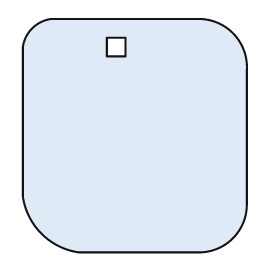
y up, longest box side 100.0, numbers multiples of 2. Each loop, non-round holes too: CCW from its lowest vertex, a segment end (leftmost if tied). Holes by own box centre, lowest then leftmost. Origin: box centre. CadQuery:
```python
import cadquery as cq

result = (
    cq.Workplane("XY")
    .moveTo(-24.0, -50.0)
    .lineTo(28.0, -50.0)
    .threePointArc((42.0, -44.0), (48.0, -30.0))
    .lineTo(48.0, 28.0)
    .threePointArc((42.0, 44.0), (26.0, 50.0))
    .lineTo(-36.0, 50.0)
    .threePointArc((-44.0, 46.0), (-48.0, 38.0))
    .lineTo(-48.0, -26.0)
    .threePointArc((-40.0, -42.0), (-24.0, -50.0))
    .close()
    .moveTo(-12.0, 34.0)
    .lineTo(-4.0, 34.0)
    .lineTo(-4.0, 42.0)
    .lineTo(-12.0, 42.0)
    .close()
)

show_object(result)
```